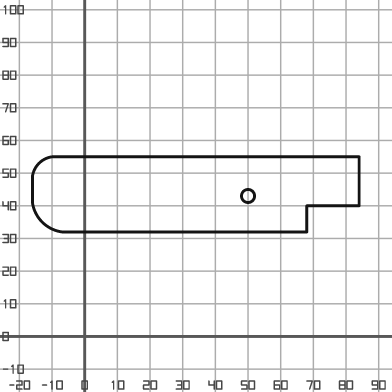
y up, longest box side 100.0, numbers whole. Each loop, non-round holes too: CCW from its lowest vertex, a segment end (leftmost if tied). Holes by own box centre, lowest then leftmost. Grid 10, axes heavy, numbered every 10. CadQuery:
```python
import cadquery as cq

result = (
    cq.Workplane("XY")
    .moveTo(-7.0, 32.0)
    .lineTo(68.0, 32.0)
    .lineTo(68.0, 40.0)
    .lineTo(84.0, 40.0)
    .lineTo(84.0, 55.0)
    .lineTo(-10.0, 55.0)
    .threePointArc((-14.0, 53.0), (-16.0, 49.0))
    .lineTo(-16.0, 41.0)
    .threePointArc((-13.0, 35.0), (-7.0, 32.0))
    .close()
    .moveTo(50.0, 43.0)
    .circle(2.0)
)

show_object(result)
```